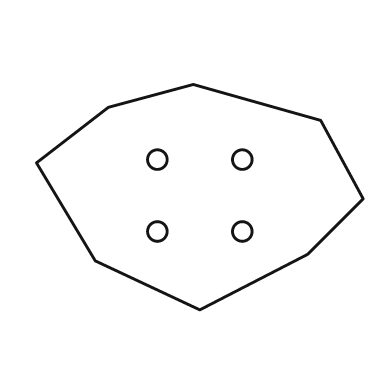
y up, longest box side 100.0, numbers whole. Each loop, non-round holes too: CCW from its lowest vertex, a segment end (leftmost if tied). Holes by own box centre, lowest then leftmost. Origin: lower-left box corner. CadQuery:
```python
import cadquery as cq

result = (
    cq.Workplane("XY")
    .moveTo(50.0, 0.0)
    .lineTo(83.0, 17.0)
    .lineTo(100.0, 34.0)
    .lineTo(87.0, 58.0)
    .lineTo(48.0, 69.0)
    .lineTo(22.0, 62.0)
    .lineTo(0.0, 45.0)
    .lineTo(18.0, 15.0)
    .close()
    .moveTo(37.0, 24.0)
    .circle(3.0)
    .moveTo(63.0, 24.0)
    .circle(3.0)
    .moveTo(37.0, 46.0)
    .circle(3.0)
    .moveTo(63.0, 46.0)
    .circle(3.0)
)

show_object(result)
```